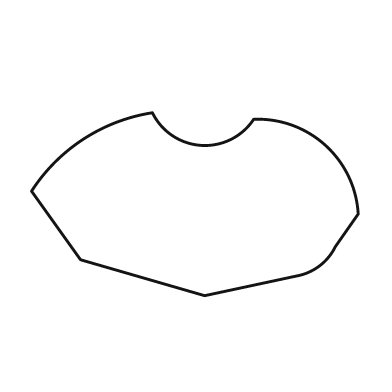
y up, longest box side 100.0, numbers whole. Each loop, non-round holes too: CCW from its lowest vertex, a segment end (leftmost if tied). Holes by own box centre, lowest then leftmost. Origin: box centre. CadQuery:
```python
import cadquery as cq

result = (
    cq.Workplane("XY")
    .moveTo(3.0, -28.0)
    .lineTo(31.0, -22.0)
    .threePointArc((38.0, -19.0), (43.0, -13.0))
    .lineTo(50.0, -3.0)
    .threePointArc((40.0, 18.0), (18.0, 26.0))
    .threePointArc((2.0, 18.0), (-13.0, 28.0))
    .threePointArc((-34.0, 20.0), (-50.0, 4.0))
    .lineTo(-35.0, -17.0)
    .close()
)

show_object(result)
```